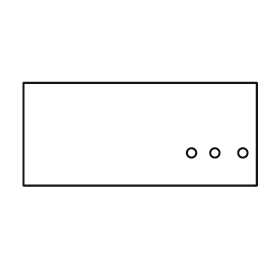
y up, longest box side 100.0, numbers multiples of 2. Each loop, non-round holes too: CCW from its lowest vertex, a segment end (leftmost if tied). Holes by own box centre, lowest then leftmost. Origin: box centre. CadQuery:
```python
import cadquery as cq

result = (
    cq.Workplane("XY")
    .moveTo(-50.0, -22.0)
    .lineTo(50.0, -22.0)
    .lineTo(50.0, 22.0)
    .lineTo(-50.0, 22.0)
    .close()
    .moveTo(22.0, -8.0)
    .circle(2.0)
    .moveTo(32.0, -8.0)
    .circle(2.0)
    .moveTo(44.0, -8.0)
    .circle(2.0)
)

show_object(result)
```